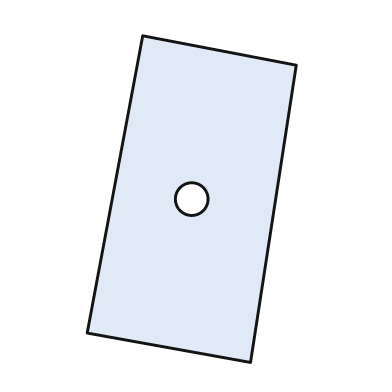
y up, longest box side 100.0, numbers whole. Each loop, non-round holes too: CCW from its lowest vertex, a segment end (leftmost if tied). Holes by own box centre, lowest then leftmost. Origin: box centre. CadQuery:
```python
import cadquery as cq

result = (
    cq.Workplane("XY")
    .moveTo(18.0, -50.0)
    .lineTo(32.0, 41.0)
    .lineTo(-15.0, 50.0)
    .lineTo(-32.0, -41.0)
    .close()
    .moveTo(0.0, 0.0)
    .circle(5.0)
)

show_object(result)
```